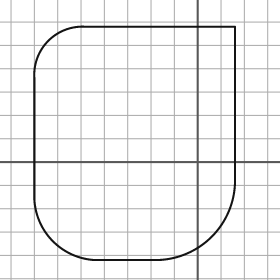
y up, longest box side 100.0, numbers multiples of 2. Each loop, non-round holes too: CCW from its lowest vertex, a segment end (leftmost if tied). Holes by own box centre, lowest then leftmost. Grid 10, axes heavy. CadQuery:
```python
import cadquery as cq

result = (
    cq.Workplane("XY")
    .moveTo(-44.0, -42.0)
    .lineTo(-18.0, -42.0)
    .threePointArc((6.0, -32.0), (16.0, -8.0))
    .lineTo(16.0, 58.0)
    .lineTo(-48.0, 58.0)
    .threePointArc((-64.0, 52.0), (-70.0, 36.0))
    .lineTo(-70.0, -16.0)
    .threePointArc((-62.0, -34.0), (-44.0, -42.0))
    .close()
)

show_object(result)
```